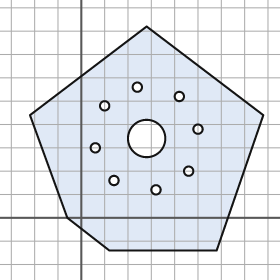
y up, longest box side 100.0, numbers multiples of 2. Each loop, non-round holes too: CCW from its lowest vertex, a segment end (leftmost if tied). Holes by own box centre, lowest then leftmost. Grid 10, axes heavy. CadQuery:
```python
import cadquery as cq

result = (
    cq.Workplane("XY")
    .moveTo(12.0, -14.0)
    .lineTo(58.0, -14.0)
    .lineTo(78.0, 44.0)
    .lineTo(28.0, 82.0)
    .lineTo(-22.0, 44.0)
    .lineTo(-6.0, 0.0)
    .close()
    .moveTo(32.0, 12.0)
    .circle(2.0)
    .moveTo(14.0, 16.0)
    .circle(2.0)
    .moveTo(46.0, 20.0)
    .circle(2.0)
    .moveTo(6.0, 30.0)
    .circle(2.0)
    .moveTo(28.0, 34.0)
    .circle(8.0)
    .moveTo(50.0, 38.0)
    .circle(2.0)
    .moveTo(10.0, 48.0)
    .circle(2.0)
    .moveTo(42.0, 52.0)
    .circle(2.0)
    .moveTo(24.0, 56.0)
    .circle(2.0)
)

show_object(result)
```